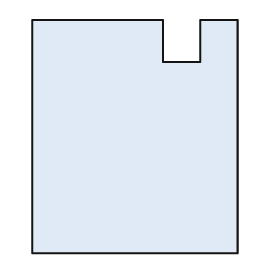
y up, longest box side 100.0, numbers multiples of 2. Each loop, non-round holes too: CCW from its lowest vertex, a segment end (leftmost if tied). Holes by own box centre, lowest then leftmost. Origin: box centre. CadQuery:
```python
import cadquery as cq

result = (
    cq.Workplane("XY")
    .moveTo(-44.0, -50.0)
    .lineTo(44.0, -50.0)
    .lineTo(44.0, 50.0)
    .lineTo(28.0, 50.0)
    .lineTo(28.0, 32.0)
    .lineTo(12.0, 32.0)
    .lineTo(12.0, 50.0)
    .lineTo(-44.0, 50.0)
    .close()
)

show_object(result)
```